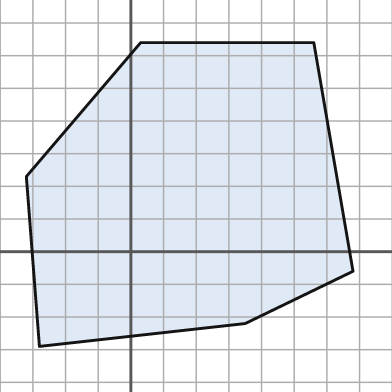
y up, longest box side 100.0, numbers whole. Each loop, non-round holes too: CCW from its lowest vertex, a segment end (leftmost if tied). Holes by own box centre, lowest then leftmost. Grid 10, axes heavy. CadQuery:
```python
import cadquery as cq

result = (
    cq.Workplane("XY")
    .moveTo(-28.0, -29.0)
    .lineTo(35.0, -22.0)
    .lineTo(68.0, -6.0)
    .lineTo(56.0, 64.0)
    .lineTo(3.0, 64.0)
    .lineTo(-32.0, 23.0)
    .close()
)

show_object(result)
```